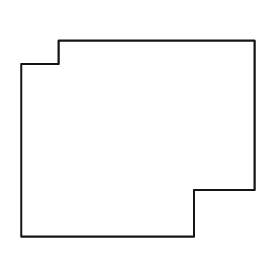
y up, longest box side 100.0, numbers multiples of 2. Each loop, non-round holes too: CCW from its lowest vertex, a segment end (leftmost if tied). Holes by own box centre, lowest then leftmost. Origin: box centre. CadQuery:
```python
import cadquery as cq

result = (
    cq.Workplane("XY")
    .moveTo(-50.0, -42.0)
    .lineTo(24.0, -42.0)
    .lineTo(24.0, -22.0)
    .lineTo(50.0, -22.0)
    .lineTo(50.0, 42.0)
    .lineTo(-34.0, 42.0)
    .lineTo(-34.0, 32.0)
    .lineTo(-50.0, 32.0)
    .close()
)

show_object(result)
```